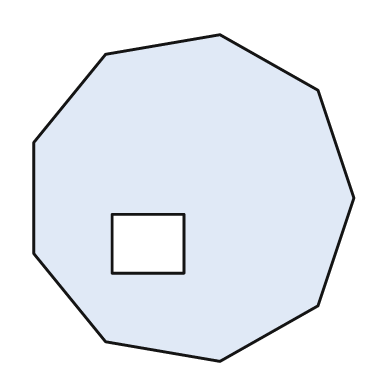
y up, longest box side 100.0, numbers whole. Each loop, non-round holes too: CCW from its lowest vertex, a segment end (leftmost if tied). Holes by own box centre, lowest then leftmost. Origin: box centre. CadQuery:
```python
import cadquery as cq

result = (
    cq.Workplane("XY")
    .moveTo(8.0, -50.0)
    .lineTo(38.0, -33.0)
    .lineTo(49.0, 0.0)
    .lineTo(38.0, 33.0)
    .lineTo(8.0, 50.0)
    .lineTo(-27.0, 44.0)
    .lineTo(-49.0, 17.0)
    .lineTo(-49.0, -17.0)
    .lineTo(-27.0, -44.0)
    .close()
    .moveTo(-25.0, -23.0)
    .lineTo(-3.0, -23.0)
    .lineTo(-3.0, -5.0)
    .lineTo(-25.0, -5.0)
    .close()
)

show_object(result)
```